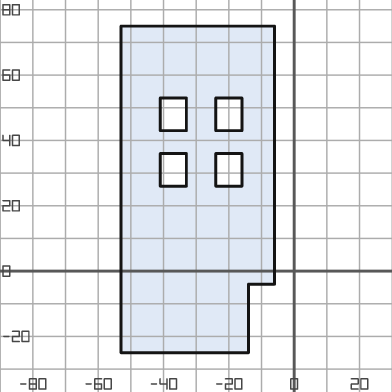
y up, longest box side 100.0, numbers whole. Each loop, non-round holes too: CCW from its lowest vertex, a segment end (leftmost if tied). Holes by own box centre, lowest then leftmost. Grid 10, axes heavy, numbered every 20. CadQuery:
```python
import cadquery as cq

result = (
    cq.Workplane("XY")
    .moveTo(-53.0, -25.0)
    .lineTo(-14.0, -25.0)
    .lineTo(-14.0, -4.0)
    .lineTo(-6.0, -4.0)
    .lineTo(-6.0, 75.0)
    .lineTo(-53.0, 75.0)
    .close()
    .moveTo(-41.0, 26.0)
    .lineTo(-33.0, 26.0)
    .lineTo(-33.0, 36.0)
    .lineTo(-41.0, 36.0)
    .close()
    .moveTo(-24.0, 26.0)
    .lineTo(-16.0, 26.0)
    .lineTo(-16.0, 36.0)
    .lineTo(-24.0, 36.0)
    .close()
    .moveTo(-41.0, 43.0)
    .lineTo(-33.0, 43.0)
    .lineTo(-33.0, 53.0)
    .lineTo(-41.0, 53.0)
    .close()
    .moveTo(-24.0, 43.0)
    .lineTo(-16.0, 43.0)
    .lineTo(-16.0, 53.0)
    .lineTo(-24.0, 53.0)
    .close()
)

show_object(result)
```